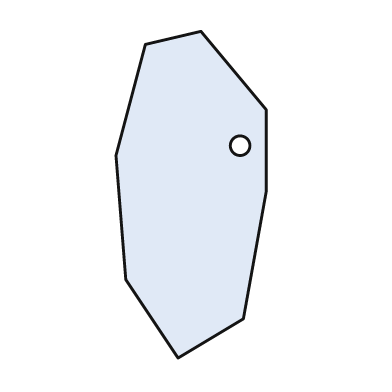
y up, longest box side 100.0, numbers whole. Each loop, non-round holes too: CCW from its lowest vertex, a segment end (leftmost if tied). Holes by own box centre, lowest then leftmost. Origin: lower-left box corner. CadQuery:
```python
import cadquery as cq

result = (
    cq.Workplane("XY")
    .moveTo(19.0, 0.0)
    .lineTo(39.0, 12.0)
    .lineTo(46.0, 51.0)
    .lineTo(46.0, 76.0)
    .lineTo(26.0, 100.0)
    .lineTo(9.0, 96.0)
    .lineTo(0.0, 62.0)
    .lineTo(3.0, 24.0)
    .close()
    .moveTo(38.0, 65.0)
    .circle(3.0)
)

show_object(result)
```